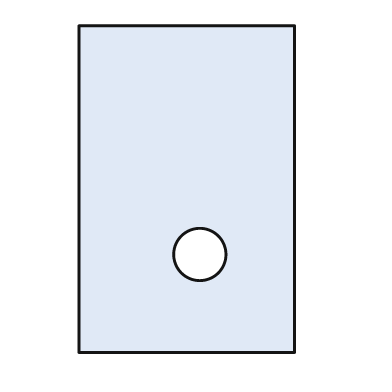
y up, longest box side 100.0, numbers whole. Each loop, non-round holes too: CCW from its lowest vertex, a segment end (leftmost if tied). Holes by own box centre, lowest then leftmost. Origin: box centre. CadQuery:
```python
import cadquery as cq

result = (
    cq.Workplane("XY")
    .moveTo(-33.0, -50.0)
    .lineTo(33.0, -50.0)
    .lineTo(33.0, 50.0)
    .lineTo(-33.0, 50.0)
    .close()
    .moveTo(4.0, -20.0)
    .circle(8.0)
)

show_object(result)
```